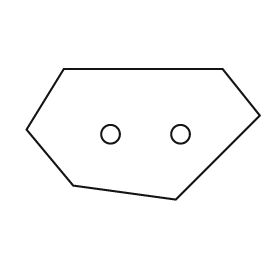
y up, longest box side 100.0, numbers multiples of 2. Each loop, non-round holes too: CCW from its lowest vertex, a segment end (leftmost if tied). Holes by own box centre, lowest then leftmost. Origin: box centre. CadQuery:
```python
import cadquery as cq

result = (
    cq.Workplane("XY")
    .moveTo(14.0, -28.0)
    .lineTo(50.0, 8.0)
    .lineTo(34.0, 28.0)
    .lineTo(-34.0, 28.0)
    .lineTo(-50.0, 2.0)
    .lineTo(-30.0, -22.0)
    .close()
    .moveTo(-14.0, 0.0)
    .circle(4.0)
    .moveTo(16.0, 0.0)
    .circle(4.0)
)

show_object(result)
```